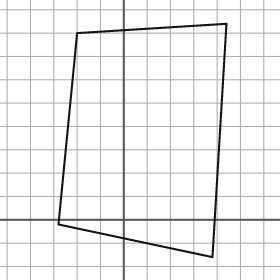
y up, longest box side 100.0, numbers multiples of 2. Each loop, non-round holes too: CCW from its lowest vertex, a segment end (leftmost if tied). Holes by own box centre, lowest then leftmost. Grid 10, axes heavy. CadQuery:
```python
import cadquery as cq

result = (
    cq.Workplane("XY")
    .moveTo(38.0, -16.0)
    .lineTo(44.0, 84.0)
    .lineTo(-20.0, 80.0)
    .lineTo(-28.0, -2.0)
    .close()
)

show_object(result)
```